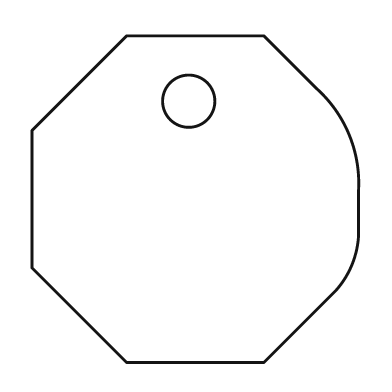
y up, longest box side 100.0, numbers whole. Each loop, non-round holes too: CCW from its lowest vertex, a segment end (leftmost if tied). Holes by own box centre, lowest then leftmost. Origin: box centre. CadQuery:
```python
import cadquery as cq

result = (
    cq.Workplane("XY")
    .moveTo(-21.0, -50.0)
    .lineTo(21.0, -50.0)
    .lineTo(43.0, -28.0)
    .threePointArc((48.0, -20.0), (50.0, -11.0))
    .lineTo(50.0, 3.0)
    .threePointArc((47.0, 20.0), (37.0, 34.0))
    .lineTo(21.0, 50.0)
    .lineTo(-21.0, 50.0)
    .lineTo(-50.0, 21.0)
    .lineTo(-50.0, -21.0)
    .close()
    .moveTo(-2.0, 30.0)
    .circle(8.0)
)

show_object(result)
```